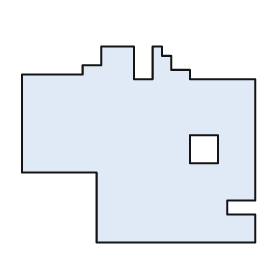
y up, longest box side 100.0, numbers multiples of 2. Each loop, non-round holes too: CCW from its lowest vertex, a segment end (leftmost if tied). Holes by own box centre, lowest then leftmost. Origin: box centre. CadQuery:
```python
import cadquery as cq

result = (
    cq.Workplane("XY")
    .moveTo(-18.0, -42.0)
    .lineTo(50.0, -42.0)
    .lineTo(50.0, -30.0)
    .lineTo(38.0, -30.0)
    .lineTo(38.0, -24.0)
    .lineTo(50.0, -24.0)
    .lineTo(50.0, 28.0)
    .lineTo(22.0, 28.0)
    .lineTo(22.0, 32.0)
    .lineTo(14.0, 32.0)
    .lineTo(14.0, 38.0)
    .lineTo(10.0, 38.0)
    .lineTo(10.0, 42.0)
    .lineTo(6.0, 42.0)
    .lineTo(6.0, 28.0)
    .lineTo(-2.0, 28.0)
    .lineTo(-2.0, 42.0)
    .lineTo(-16.0, 42.0)
    .lineTo(-16.0, 34.0)
    .lineTo(-24.0, 34.0)
    .lineTo(-24.0, 30.0)
    .lineTo(-50.0, 30.0)
    .lineTo(-50.0, -12.0)
    .lineTo(-18.0, -12.0)
    .close()
    .moveTo(22.0, -8.0)
    .lineTo(34.0, -8.0)
    .lineTo(34.0, 4.0)
    .lineTo(22.0, 4.0)
    .close()
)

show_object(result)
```